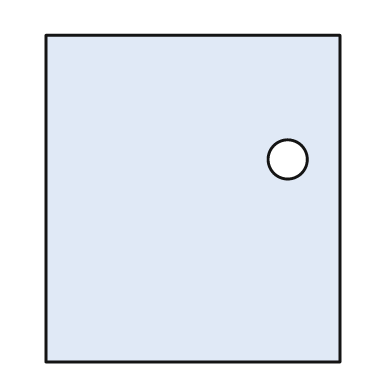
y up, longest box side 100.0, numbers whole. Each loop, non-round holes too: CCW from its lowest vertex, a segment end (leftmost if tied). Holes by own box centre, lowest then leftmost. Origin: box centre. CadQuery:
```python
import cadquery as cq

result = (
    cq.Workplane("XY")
    .moveTo(-45.0, -50.0)
    .lineTo(45.0, -50.0)
    .lineTo(45.0, 50.0)
    .lineTo(-45.0, 50.0)
    .close()
    .moveTo(29.0, 12.0)
    .circle(6.0)
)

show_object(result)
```